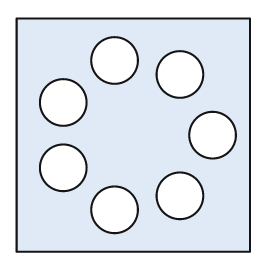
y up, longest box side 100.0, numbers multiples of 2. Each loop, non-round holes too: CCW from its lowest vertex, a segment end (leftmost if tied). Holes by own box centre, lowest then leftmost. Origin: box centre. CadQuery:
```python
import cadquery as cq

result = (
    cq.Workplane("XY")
    .moveTo(-50.0, -50.0)
    .lineTo(50.0, -50.0)
    .lineTo(50.0, 50.0)
    .lineTo(-50.0, 50.0)
    .close()
    .moveTo(-8.0, -32.0)
    .circle(10.0)
    .moveTo(20.0, -26.0)
    .circle(10.0)
    .moveTo(-30.0, -14.0)
    .circle(10.0)
    .moveTo(34.0, 0.0)
    .circle(10.0)
    .moveTo(-30.0, 14.0)
    .circle(10.0)
    .moveTo(20.0, 26.0)
    .circle(10.0)
    .moveTo(-8.0, 32.0)
    .circle(10.0)
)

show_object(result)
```